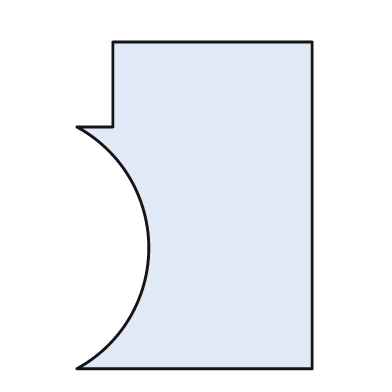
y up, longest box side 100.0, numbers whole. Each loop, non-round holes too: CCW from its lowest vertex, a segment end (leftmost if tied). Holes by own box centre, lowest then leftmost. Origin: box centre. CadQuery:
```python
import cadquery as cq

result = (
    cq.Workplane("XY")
    .moveTo(-36.0, -50.0)
    .lineTo(36.0, -50.0)
    .lineTo(36.0, 50.0)
    .lineTo(-25.0, 50.0)
    .lineTo(-25.0, 24.0)
    .lineTo(-36.0, 24.0)
    .threePointArc((-14.0, -13.0), (-36.0, -50.0))
    .close()
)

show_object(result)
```